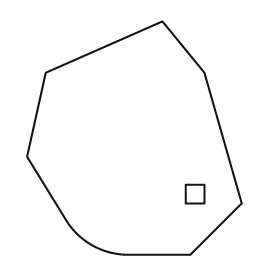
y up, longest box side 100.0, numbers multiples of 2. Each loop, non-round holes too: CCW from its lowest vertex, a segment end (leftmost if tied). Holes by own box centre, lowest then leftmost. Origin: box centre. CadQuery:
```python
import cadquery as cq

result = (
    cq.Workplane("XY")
    .moveTo(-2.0, -50.0)
    .lineTo(24.0, -50.0)
    .lineTo(46.0, -28.0)
    .lineTo(30.0, 28.0)
    .lineTo(12.0, 50.0)
    .lineTo(-38.0, 28.0)
    .lineTo(-46.0, -8.0)
    .lineTo(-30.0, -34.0)
    .threePointArc((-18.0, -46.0), (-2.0, -50.0))
    .close()
    .moveTo(22.0, -28.0)
    .lineTo(30.0, -28.0)
    .lineTo(30.0, -20.0)
    .lineTo(22.0, -20.0)
    .close()
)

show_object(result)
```